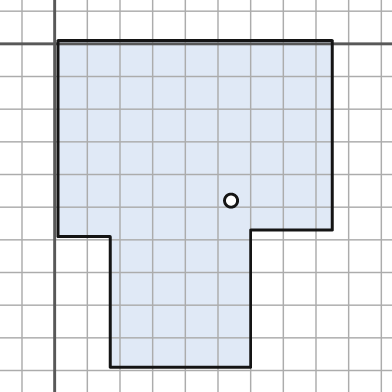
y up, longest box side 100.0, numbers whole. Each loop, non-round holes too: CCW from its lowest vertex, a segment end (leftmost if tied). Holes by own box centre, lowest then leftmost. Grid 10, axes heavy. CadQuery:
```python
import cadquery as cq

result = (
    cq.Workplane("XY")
    .moveTo(17.0, -99.0)
    .lineTo(60.0, -99.0)
    .lineTo(60.0, -57.0)
    .lineTo(85.0, -57.0)
    .lineTo(85.0, 1.0)
    .lineTo(1.0, 1.0)
    .lineTo(1.0, -59.0)
    .lineTo(17.0, -59.0)
    .close()
    .moveTo(54.0, -48.0)
    .circle(2.0)
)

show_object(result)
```